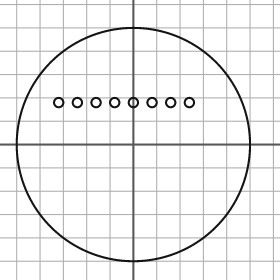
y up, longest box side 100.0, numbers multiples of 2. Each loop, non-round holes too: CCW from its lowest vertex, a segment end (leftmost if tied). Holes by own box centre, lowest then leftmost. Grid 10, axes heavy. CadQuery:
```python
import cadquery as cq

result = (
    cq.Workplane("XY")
    .moveTo(0.0, 0.0)
    .circle(50.0)
    .moveTo(-32.0, 18.0)
    .circle(2.0)
    .moveTo(-24.0, 18.0)
    .circle(2.0)
    .moveTo(-16.0, 18.0)
    .circle(2.0)
    .moveTo(-8.0, 18.0)
    .circle(2.0)
    .moveTo(0.0, 18.0)
    .circle(2.0)
    .moveTo(8.0, 18.0)
    .circle(2.0)
    .moveTo(16.0, 18.0)
    .circle(2.0)
    .moveTo(24.0, 18.0)
    .circle(2.0)
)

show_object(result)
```